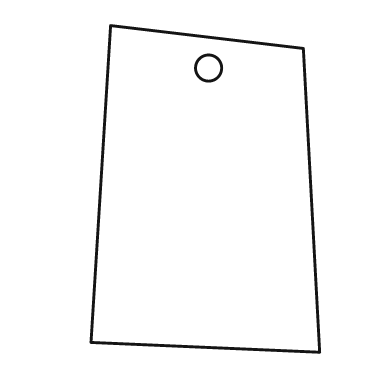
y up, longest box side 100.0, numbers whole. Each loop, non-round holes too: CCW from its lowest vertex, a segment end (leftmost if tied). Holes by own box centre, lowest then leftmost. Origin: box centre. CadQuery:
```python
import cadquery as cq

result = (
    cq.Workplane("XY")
    .moveTo(35.0, -50.0)
    .lineTo(30.0, 43.0)
    .lineTo(-29.0, 50.0)
    .lineTo(-35.0, -47.0)
    .close()
    .moveTo(1.0, 37.0)
    .circle(4.0)
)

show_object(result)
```